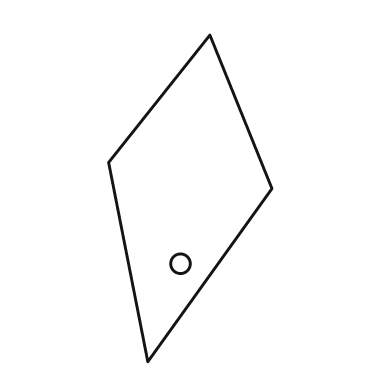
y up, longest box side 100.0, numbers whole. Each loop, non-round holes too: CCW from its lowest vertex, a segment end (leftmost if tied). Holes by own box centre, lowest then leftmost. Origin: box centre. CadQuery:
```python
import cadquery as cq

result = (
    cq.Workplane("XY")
    .moveTo(-13.0, -50.0)
    .lineTo(25.0, 3.0)
    .lineTo(6.0, 50.0)
    .lineTo(-25.0, 11.0)
    .close()
    .moveTo(-3.0, -20.0)
    .circle(3.0)
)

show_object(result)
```